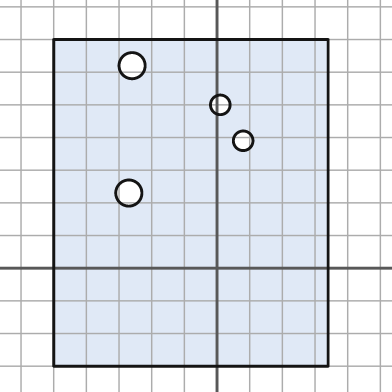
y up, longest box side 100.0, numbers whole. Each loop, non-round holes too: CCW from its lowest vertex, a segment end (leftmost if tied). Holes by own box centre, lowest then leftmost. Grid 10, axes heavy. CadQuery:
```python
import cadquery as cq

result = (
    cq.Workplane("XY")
    .moveTo(-50.0, -30.0)
    .lineTo(34.0, -30.0)
    .lineTo(34.0, 70.0)
    .lineTo(-50.0, 70.0)
    .close()
    .moveTo(-27.0, 23.0)
    .circle(4.0)
    .moveTo(8.0, 39.0)
    .circle(3.0)
    .moveTo(1.0, 50.0)
    .circle(3.0)
    .moveTo(-26.0, 62.0)
    .circle(4.0)
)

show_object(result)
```